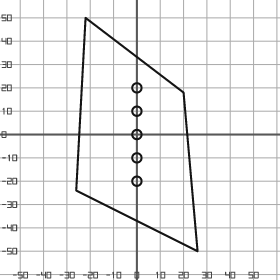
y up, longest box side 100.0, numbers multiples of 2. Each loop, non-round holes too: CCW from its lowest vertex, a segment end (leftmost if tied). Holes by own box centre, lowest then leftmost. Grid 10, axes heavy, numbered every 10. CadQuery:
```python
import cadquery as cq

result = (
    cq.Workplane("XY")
    .moveTo(26.0, -50.0)
    .lineTo(20.0, 18.0)
    .lineTo(-22.0, 50.0)
    .lineTo(-26.0, -24.0)
    .close()
    .moveTo(0.0, -20.0)
    .circle(2.0)
    .moveTo(0.0, -10.0)
    .circle(2.0)
    .moveTo(0.0, 0.0)
    .circle(2.0)
    .moveTo(0.0, 10.0)
    .circle(2.0)
    .moveTo(0.0, 20.0)
    .circle(2.0)
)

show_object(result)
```